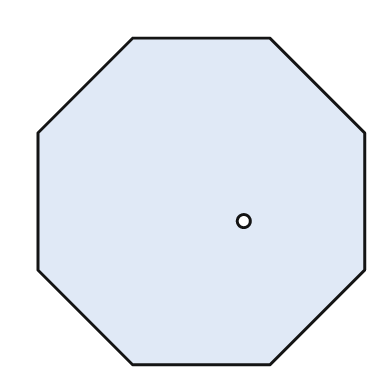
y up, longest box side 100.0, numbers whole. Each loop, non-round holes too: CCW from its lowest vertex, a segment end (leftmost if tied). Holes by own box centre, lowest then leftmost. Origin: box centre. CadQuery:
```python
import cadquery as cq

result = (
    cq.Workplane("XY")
    .moveTo(-21.0, -50.0)
    .lineTo(21.0, -50.0)
    .lineTo(50.0, -21.0)
    .lineTo(50.0, 21.0)
    .lineTo(21.0, 50.0)
    .lineTo(-21.0, 50.0)
    .lineTo(-50.0, 21.0)
    .lineTo(-50.0, -21.0)
    .close()
    .moveTo(13.0, -6.0)
    .circle(2.0)
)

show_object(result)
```